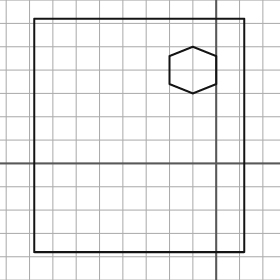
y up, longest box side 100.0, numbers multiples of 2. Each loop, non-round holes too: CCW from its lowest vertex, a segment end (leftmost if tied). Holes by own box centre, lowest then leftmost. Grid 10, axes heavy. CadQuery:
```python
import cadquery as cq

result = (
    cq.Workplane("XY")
    .moveTo(-78.0, -38.0)
    .lineTo(12.0, -38.0)
    .lineTo(12.0, 62.0)
    .lineTo(-78.0, 62.0)
    .close()
    .moveTo(-10.0, 30.0)
    .lineTo(0.0, 34.0)
    .lineTo(0.0, 46.0)
    .lineTo(-10.0, 50.0)
    .lineTo(-20.0, 46.0)
    .lineTo(-20.0, 34.0)
    .close()
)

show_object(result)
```